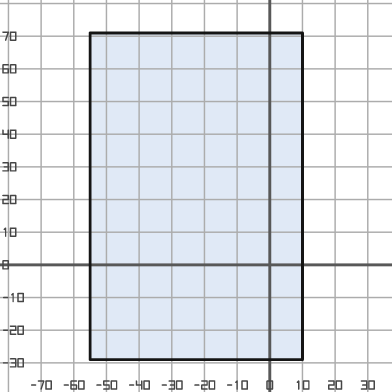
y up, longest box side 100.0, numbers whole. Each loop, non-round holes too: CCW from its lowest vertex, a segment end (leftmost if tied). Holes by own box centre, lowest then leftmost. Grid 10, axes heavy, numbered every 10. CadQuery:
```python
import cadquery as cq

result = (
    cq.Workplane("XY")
    .moveTo(-55.0, -29.0)
    .lineTo(10.0, -29.0)
    .lineTo(10.0, 71.0)
    .lineTo(-55.0, 71.0)
    .close()
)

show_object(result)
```